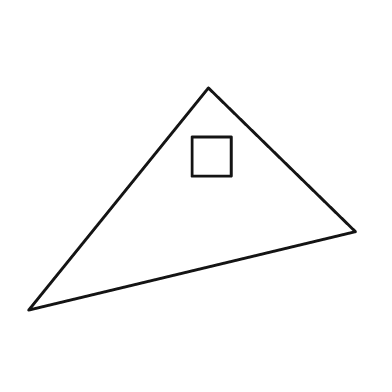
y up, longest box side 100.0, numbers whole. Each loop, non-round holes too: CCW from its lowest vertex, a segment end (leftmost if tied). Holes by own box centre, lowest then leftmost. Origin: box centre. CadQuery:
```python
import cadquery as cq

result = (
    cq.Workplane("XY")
    .moveTo(-50.0, -34.0)
    .lineTo(50.0, -10.0)
    .lineTo(5.0, 34.0)
    .close()
    .moveTo(0.0, 7.0)
    .lineTo(12.0, 7.0)
    .lineTo(12.0, 19.0)
    .lineTo(0.0, 19.0)
    .close()
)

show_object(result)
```